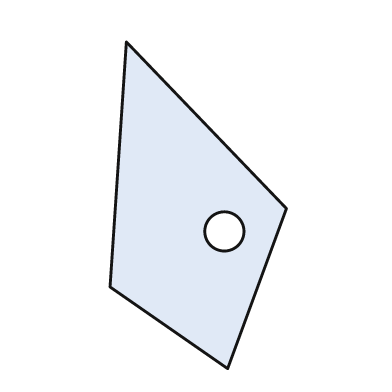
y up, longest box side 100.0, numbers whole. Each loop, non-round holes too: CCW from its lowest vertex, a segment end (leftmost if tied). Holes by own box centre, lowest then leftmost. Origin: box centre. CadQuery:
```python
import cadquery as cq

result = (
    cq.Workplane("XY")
    .moveTo(9.0, -50.0)
    .lineTo(27.0, -1.0)
    .lineTo(-22.0, 50.0)
    .lineTo(-27.0, -25.0)
    .close()
    .moveTo(8.0, -8.0)
    .circle(6.0)
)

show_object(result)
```